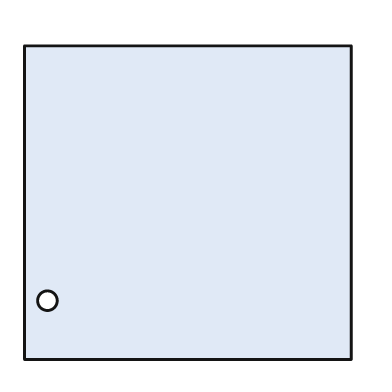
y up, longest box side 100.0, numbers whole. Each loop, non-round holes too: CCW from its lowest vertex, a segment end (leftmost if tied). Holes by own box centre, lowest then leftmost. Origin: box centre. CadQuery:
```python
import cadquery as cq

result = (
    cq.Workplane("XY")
    .moveTo(-50.0, -48.0)
    .lineTo(50.0, -48.0)
    .lineTo(50.0, 48.0)
    .lineTo(-50.0, 48.0)
    .close()
    .moveTo(-43.0, -30.0)
    .circle(3.0)
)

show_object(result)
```